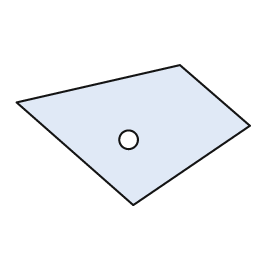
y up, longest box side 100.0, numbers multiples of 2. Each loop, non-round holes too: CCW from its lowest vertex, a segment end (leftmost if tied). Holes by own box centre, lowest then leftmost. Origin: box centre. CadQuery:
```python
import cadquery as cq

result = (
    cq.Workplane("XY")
    .moveTo(0.0, -30.0)
    .lineTo(50.0, 4.0)
    .lineTo(20.0, 30.0)
    .lineTo(-50.0, 14.0)
    .close()
    .moveTo(-2.0, -2.0)
    .circle(4.0)
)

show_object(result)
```